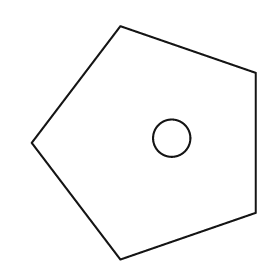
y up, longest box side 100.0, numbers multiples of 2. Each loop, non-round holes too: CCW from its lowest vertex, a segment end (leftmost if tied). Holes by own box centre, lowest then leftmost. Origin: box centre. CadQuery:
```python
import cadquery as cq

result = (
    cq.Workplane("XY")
    .moveTo(-10.0, -50.0)
    .lineTo(48.0, -30.0)
    .lineTo(48.0, 30.0)
    .lineTo(-10.0, 50.0)
    .lineTo(-48.0, 0.0)
    .close()
    .moveTo(12.0, 2.0)
    .circle(8.0)
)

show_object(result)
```